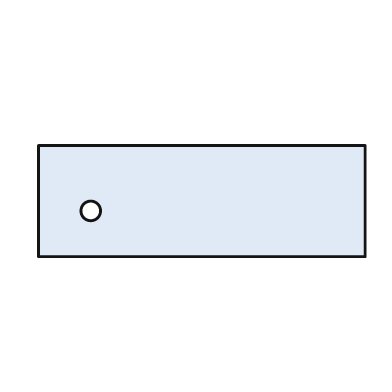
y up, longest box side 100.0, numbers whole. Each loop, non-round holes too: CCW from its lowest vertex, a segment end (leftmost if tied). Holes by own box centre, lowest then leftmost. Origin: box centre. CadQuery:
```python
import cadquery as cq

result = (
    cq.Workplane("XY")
    .moveTo(-50.0, -17.0)
    .lineTo(50.0, -17.0)
    .lineTo(50.0, 17.0)
    .lineTo(-50.0, 17.0)
    .close()
    .moveTo(-34.0, -3.0)
    .circle(3.0)
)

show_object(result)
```